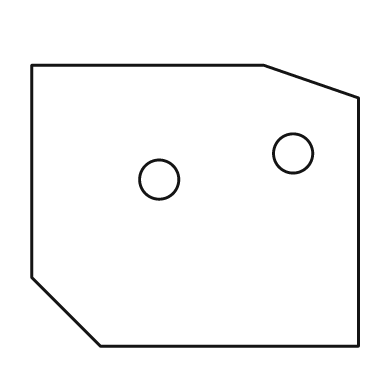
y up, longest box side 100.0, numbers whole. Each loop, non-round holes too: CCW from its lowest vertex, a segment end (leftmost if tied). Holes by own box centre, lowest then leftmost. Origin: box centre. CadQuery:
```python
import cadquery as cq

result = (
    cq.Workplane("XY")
    .moveTo(-29.0, -43.0)
    .lineTo(50.0, -43.0)
    .lineTo(50.0, 33.0)
    .lineTo(21.0, 43.0)
    .lineTo(-50.0, 43.0)
    .lineTo(-50.0, -22.0)
    .close()
    .moveTo(-11.0, 8.0)
    .circle(6.0)
    .moveTo(30.0, 16.0)
    .circle(6.0)
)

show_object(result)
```